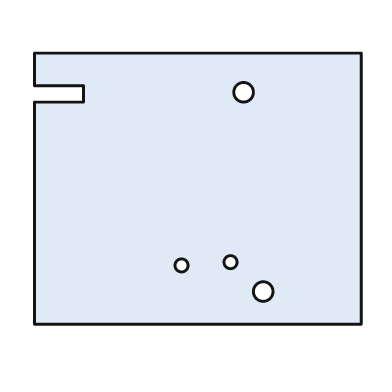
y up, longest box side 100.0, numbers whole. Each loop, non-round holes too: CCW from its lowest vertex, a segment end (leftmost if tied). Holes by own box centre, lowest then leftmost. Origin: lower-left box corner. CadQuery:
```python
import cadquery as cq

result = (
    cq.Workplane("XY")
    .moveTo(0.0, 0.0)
    .lineTo(100.0, 0.0)
    .lineTo(100.0, 83.0)
    .lineTo(0.0, 83.0)
    .lineTo(0.0, 73.0)
    .lineTo(15.0, 73.0)
    .lineTo(15.0, 68.0)
    .lineTo(0.0, 68.0)
    .close()
    .moveTo(70.0, 10.0)
    .circle(3.0)
    .moveTo(45.0, 18.0)
    .circle(2.0)
    .moveTo(60.0, 19.0)
    .circle(2.0)
    .moveTo(64.0, 71.0)
    .circle(3.0)
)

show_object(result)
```